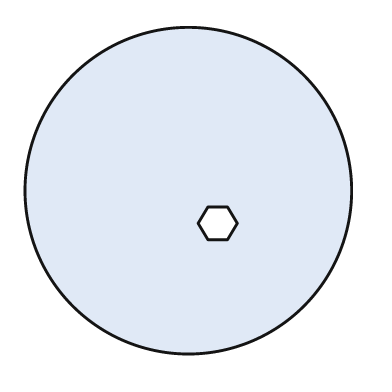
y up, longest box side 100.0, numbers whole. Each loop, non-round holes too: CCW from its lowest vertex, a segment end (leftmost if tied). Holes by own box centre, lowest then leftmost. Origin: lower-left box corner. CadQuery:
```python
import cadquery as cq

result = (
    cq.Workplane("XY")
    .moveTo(50.0, 50.0)
    .circle(50.0)
    .moveTo(56.0, 35.0)
    .lineTo(62.0, 35.0)
    .lineTo(65.0, 40.0)
    .lineTo(62.0, 45.0)
    .lineTo(56.0, 45.0)
    .lineTo(53.0, 40.0)
    .close()
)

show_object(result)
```